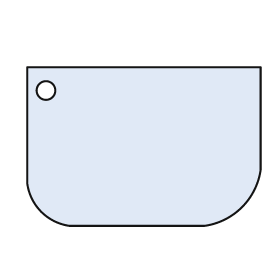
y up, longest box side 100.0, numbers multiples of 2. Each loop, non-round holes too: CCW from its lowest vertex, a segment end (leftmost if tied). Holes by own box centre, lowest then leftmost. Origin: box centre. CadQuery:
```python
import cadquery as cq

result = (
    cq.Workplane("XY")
    .moveTo(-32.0, -34.0)
    .lineTo(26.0, -34.0)
    .threePointArc((42.0, -26.0), (50.0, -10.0))
    .lineTo(50.0, 34.0)
    .lineTo(-50.0, 34.0)
    .lineTo(-50.0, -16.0)
    .threePointArc((-44.0, -28.0), (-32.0, -34.0))
    .close()
    .moveTo(-42.0, 24.0)
    .circle(4.0)
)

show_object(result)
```